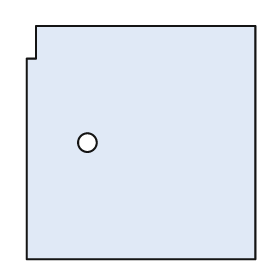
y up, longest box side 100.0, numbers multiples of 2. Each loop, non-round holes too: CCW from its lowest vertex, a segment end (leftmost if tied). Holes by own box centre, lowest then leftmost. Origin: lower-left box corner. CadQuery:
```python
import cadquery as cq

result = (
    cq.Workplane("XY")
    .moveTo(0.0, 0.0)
    .lineTo(98.0, 0.0)
    .lineTo(98.0, 100.0)
    .lineTo(4.0, 100.0)
    .lineTo(4.0, 86.0)
    .lineTo(0.0, 86.0)
    .close()
    .moveTo(26.0, 50.0)
    .circle(4.0)
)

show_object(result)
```